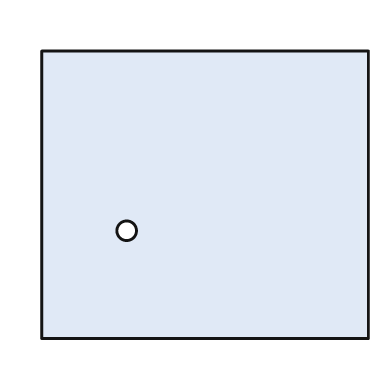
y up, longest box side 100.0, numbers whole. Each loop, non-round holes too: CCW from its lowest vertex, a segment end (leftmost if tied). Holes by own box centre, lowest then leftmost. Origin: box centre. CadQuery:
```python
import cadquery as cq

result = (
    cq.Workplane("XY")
    .moveTo(-50.0, -44.0)
    .lineTo(50.0, -44.0)
    .lineTo(50.0, 44.0)
    .lineTo(-50.0, 44.0)
    .close()
    .moveTo(-24.0, -11.0)
    .circle(3.0)
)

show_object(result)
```